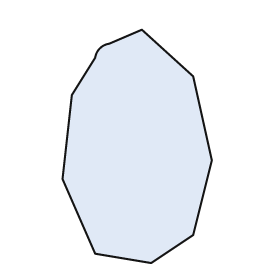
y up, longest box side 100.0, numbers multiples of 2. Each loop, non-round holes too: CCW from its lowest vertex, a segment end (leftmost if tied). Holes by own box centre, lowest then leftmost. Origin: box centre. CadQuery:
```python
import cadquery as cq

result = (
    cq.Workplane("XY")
    .moveTo(6.0, -50.0)
    .lineTo(24.0, -38.0)
    .lineTo(32.0, -6.0)
    .lineTo(24.0, 30.0)
    .lineTo(2.0, 50.0)
    .lineTo(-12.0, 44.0)
    .threePointArc((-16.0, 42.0), (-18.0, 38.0))
    .lineTo(-28.0, 22.0)
    .lineTo(-32.0, -14.0)
    .lineTo(-18.0, -46.0)
    .close()
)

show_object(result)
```